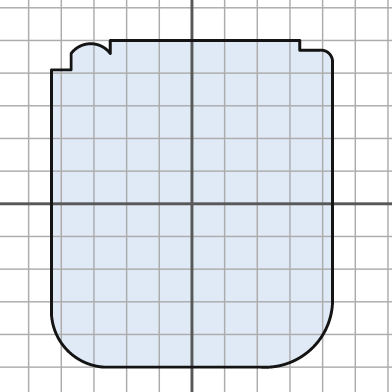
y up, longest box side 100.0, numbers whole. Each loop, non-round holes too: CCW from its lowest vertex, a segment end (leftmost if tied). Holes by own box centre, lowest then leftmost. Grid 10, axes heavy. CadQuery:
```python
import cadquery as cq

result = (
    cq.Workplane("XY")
    .moveTo(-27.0, -50.0)
    .lineTo(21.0, -50.0)
    .threePointArc((37.0, -44.0), (43.0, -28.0))
    .lineTo(43.0, 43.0)
    .threePointArc((42.0, 46.0), (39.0, 47.0))
    .lineTo(33.0, 47.0)
    .lineTo(33.0, 50.0)
    .lineTo(-25.0, 50.0)
    .lineTo(-25.0, 46.0)
    .threePointArc((-31.0, 49.0), (-37.0, 46.0))
    .lineTo(-37.0, 41.0)
    .lineTo(-43.0, 41.0)
    .lineTo(-43.0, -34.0)
    .threePointArc((-38.0, -45.0), (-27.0, -50.0))
    .close()
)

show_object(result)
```